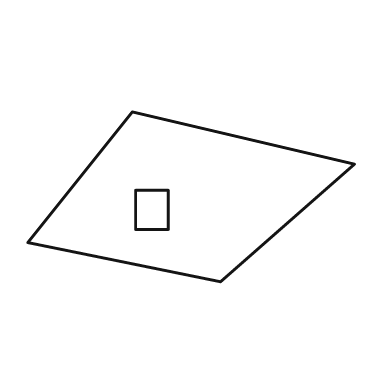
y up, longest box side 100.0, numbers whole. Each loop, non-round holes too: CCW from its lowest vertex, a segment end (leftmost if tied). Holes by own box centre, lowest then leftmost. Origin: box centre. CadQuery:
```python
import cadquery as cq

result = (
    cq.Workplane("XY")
    .moveTo(9.0, -26.0)
    .lineTo(50.0, 10.0)
    .lineTo(-18.0, 26.0)
    .lineTo(-50.0, -14.0)
    .close()
    .moveTo(-17.0, -10.0)
    .lineTo(-7.0, -10.0)
    .lineTo(-7.0, 2.0)
    .lineTo(-17.0, 2.0)
    .close()
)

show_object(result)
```